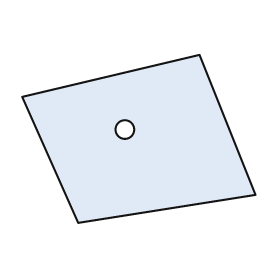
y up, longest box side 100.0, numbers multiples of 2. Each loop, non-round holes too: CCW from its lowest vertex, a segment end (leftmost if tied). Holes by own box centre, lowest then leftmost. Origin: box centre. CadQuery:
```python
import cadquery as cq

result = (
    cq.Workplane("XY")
    .moveTo(-26.0, -36.0)
    .lineTo(50.0, -24.0)
    .lineTo(26.0, 36.0)
    .lineTo(-50.0, 18.0)
    .close()
    .moveTo(-6.0, 4.0)
    .circle(4.0)
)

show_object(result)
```